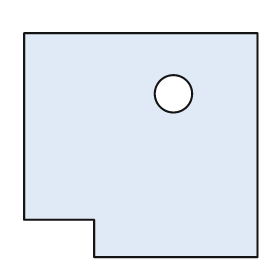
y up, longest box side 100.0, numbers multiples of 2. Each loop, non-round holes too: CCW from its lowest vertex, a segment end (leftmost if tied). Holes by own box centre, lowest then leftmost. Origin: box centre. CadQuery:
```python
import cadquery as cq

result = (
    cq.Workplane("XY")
    .moveTo(-20.0, -48.0)
    .lineTo(50.0, -48.0)
    .lineTo(50.0, 48.0)
    .lineTo(-50.0, 48.0)
    .lineTo(-50.0, -32.0)
    .lineTo(-20.0, -32.0)
    .close()
    .moveTo(14.0, 22.0)
    .circle(8.0)
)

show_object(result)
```